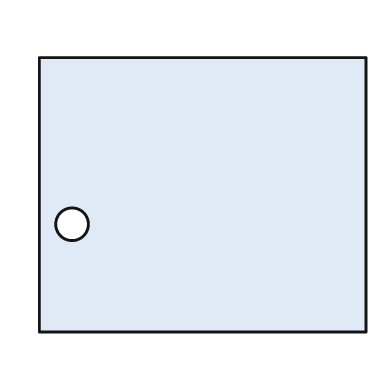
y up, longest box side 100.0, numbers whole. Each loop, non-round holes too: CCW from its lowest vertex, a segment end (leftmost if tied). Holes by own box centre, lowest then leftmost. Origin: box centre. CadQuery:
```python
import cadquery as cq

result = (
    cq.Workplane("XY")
    .moveTo(-50.0, -42.0)
    .lineTo(50.0, -42.0)
    .lineTo(50.0, 42.0)
    .lineTo(-50.0, 42.0)
    .close()
    .moveTo(-40.0, -9.0)
    .circle(5.0)
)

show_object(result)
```